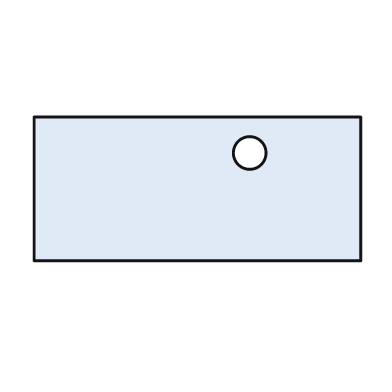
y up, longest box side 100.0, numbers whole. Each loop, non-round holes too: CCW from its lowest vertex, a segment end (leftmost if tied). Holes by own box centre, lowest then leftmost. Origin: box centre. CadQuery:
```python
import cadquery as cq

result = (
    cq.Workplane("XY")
    .moveTo(-50.0, -22.0)
    .lineTo(50.0, -22.0)
    .lineTo(50.0, 22.0)
    .lineTo(-50.0, 22.0)
    .close()
    .moveTo(16.0, 11.0)
    .circle(5.0)
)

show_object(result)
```